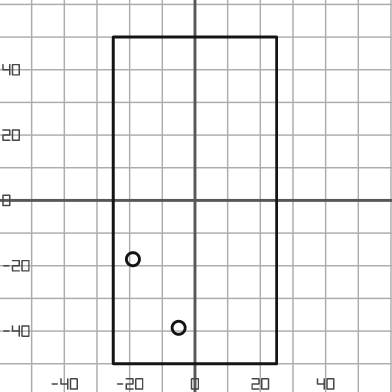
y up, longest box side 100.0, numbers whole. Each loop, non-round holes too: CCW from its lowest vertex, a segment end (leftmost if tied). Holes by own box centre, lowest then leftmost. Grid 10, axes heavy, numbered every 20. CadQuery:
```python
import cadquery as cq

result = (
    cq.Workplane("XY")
    .moveTo(-25.0, -50.0)
    .lineTo(25.0, -50.0)
    .lineTo(25.0, 50.0)
    .lineTo(-25.0, 50.0)
    .close()
    .moveTo(-5.0, -39.0)
    .circle(2.0)
    .moveTo(-19.0, -18.0)
    .circle(2.0)
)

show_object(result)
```